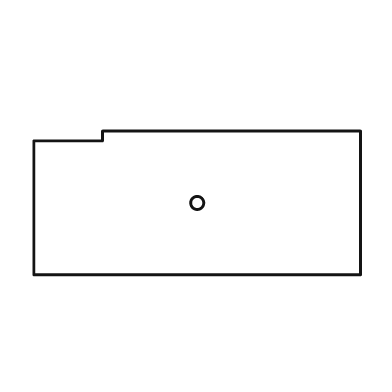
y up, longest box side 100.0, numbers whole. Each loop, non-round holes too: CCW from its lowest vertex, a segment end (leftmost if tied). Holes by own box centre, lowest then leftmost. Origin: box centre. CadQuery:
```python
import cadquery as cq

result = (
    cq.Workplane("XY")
    .moveTo(-50.0, -22.0)
    .lineTo(50.0, -22.0)
    .lineTo(50.0, 22.0)
    .lineTo(-29.0, 22.0)
    .lineTo(-29.0, 19.0)
    .lineTo(-50.0, 19.0)
    .close()
    .moveTo(0.0, 0.0)
    .circle(2.0)
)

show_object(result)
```